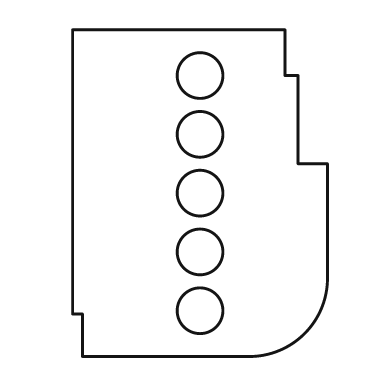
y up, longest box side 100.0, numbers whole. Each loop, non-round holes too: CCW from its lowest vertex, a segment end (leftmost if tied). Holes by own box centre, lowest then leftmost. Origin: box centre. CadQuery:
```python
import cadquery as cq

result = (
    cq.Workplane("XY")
    .moveTo(-36.0, -50.0)
    .lineTo(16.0, -50.0)
    .threePointArc((32.0, -43.0), (39.0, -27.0))
    .lineTo(39.0, 9.0)
    .lineTo(30.0, 9.0)
    .lineTo(30.0, 36.0)
    .lineTo(26.0, 36.0)
    .lineTo(26.0, 50.0)
    .lineTo(-39.0, 50.0)
    .lineTo(-39.0, -37.0)
    .lineTo(-36.0, -37.0)
    .close()
    .moveTo(0.0, -36.0)
    .circle(7.0)
    .moveTo(0.0, -18.0)
    .circle(7.0)
    .moveTo(0.0, 0.0)
    .circle(7.0)
    .moveTo(0.0, 18.0)
    .circle(7.0)
    .moveTo(0.0, 36.0)
    .circle(7.0)
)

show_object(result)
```